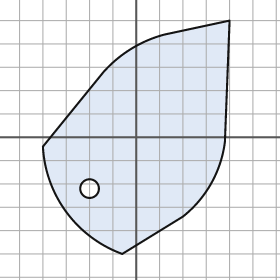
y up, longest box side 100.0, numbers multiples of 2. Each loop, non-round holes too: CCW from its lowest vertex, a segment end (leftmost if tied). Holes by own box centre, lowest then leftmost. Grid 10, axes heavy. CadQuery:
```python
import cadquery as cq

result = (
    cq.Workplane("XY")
    .moveTo(-6.0, -50.0)
    .lineTo(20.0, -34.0)
    .threePointArc((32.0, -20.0), (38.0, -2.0))
    .lineTo(40.0, 50.0)
    .lineTo(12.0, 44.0)
    .threePointArc((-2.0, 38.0), (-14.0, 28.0))
    .lineTo(-40.0, -4.0)
    .threePointArc((-30.0, -32.0), (-6.0, -50.0))
    .close()
    .moveTo(-20.0, -22.0)
    .circle(4.0)
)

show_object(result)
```